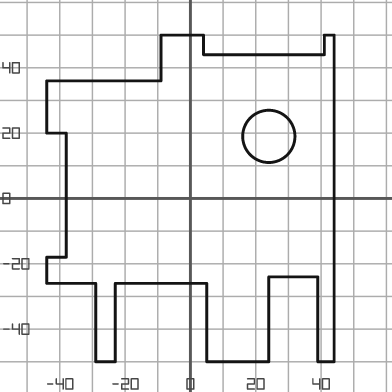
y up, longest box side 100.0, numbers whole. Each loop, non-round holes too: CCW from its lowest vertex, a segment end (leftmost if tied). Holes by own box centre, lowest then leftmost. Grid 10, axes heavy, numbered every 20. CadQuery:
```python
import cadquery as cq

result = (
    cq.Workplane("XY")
    .moveTo(-29.0, -50.0)
    .lineTo(-23.0, -50.0)
    .lineTo(-23.0, -26.0)
    .lineTo(5.0, -26.0)
    .lineTo(5.0, -50.0)
    .lineTo(24.0, -50.0)
    .lineTo(24.0, -24.0)
    .lineTo(39.0, -24.0)
    .lineTo(39.0, -50.0)
    .lineTo(44.0, -50.0)
    .lineTo(44.0, 50.0)
    .lineTo(41.0, 50.0)
    .lineTo(41.0, 44.0)
    .lineTo(4.0, 44.0)
    .lineTo(4.0, 50.0)
    .lineTo(-9.0, 50.0)
    .lineTo(-9.0, 36.0)
    .lineTo(-44.0, 36.0)
    .lineTo(-44.0, 20.0)
    .lineTo(-38.0, 20.0)
    .lineTo(-38.0, -18.0)
    .lineTo(-44.0, -18.0)
    .lineTo(-44.0, -26.0)
    .lineTo(-29.0, -26.0)
    .close()
    .moveTo(24.0, 19.0)
    .circle(8.0)
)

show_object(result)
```